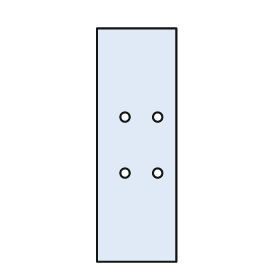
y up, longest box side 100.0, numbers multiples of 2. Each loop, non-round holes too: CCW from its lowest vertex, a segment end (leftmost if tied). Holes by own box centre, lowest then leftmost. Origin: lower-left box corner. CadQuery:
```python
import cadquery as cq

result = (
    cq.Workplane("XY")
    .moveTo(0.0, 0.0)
    .lineTo(34.0, 0.0)
    .lineTo(34.0, 100.0)
    .lineTo(0.0, 100.0)
    .close()
    .moveTo(12.0, 38.0)
    .circle(2.0)
    .moveTo(26.0, 38.0)
    .circle(2.0)
    .moveTo(12.0, 62.0)
    .circle(2.0)
    .moveTo(26.0, 62.0)
    .circle(2.0)
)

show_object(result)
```